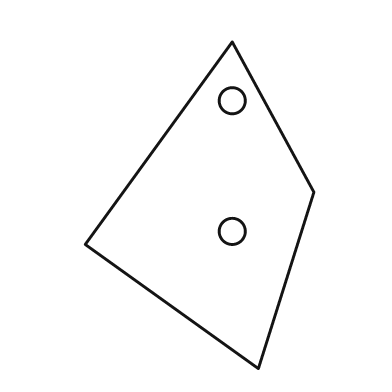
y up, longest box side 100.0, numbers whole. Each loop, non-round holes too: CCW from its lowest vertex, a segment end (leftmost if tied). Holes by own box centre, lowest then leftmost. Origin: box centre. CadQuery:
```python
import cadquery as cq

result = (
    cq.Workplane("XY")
    .moveTo(18.0, -50.0)
    .lineTo(35.0, 4.0)
    .lineTo(10.0, 50.0)
    .lineTo(-35.0, -12.0)
    .close()
    .moveTo(10.0, -8.0)
    .circle(4.0)
    .moveTo(10.0, 32.0)
    .circle(4.0)
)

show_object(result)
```